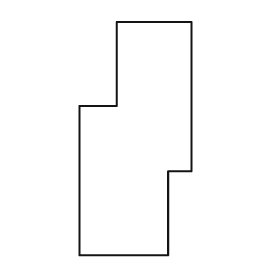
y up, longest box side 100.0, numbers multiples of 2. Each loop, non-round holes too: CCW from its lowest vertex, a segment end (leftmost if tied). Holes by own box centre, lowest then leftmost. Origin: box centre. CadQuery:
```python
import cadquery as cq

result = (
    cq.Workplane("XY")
    .moveTo(-24.0, -50.0)
    .lineTo(14.0, -50.0)
    .lineTo(14.0, -14.0)
    .lineTo(24.0, -14.0)
    .lineTo(24.0, 50.0)
    .lineTo(-8.0, 50.0)
    .lineTo(-8.0, 14.0)
    .lineTo(-24.0, 14.0)
    .close()
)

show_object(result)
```